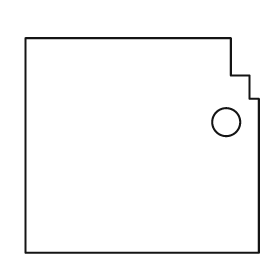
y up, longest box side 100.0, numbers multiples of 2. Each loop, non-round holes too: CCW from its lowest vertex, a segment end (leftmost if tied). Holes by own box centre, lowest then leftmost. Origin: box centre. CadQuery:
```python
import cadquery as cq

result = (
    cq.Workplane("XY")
    .moveTo(-50.0, -46.0)
    .lineTo(50.0, -46.0)
    .lineTo(50.0, 20.0)
    .lineTo(46.0, 20.0)
    .lineTo(46.0, 30.0)
    .lineTo(38.0, 30.0)
    .lineTo(38.0, 46.0)
    .lineTo(-50.0, 46.0)
    .close()
    .moveTo(36.0, 10.0)
    .circle(6.0)
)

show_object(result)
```